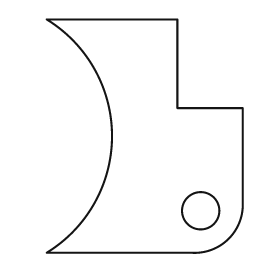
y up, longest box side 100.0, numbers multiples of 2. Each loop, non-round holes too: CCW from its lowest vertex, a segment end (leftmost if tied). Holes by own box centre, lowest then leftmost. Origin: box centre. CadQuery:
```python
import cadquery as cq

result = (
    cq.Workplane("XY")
    .moveTo(-42.0, -50.0)
    .lineTo(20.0, -50.0)
    .threePointArc((36.0, -44.0), (42.0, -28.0))
    .lineTo(42.0, 12.0)
    .lineTo(14.0, 12.0)
    .lineTo(14.0, 50.0)
    .lineTo(-42.0, 50.0)
    .threePointArc((-14.0, 0.0), (-42.0, -50.0))
    .close()
    .moveTo(24.0, -32.0)
    .circle(8.0)
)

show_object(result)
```